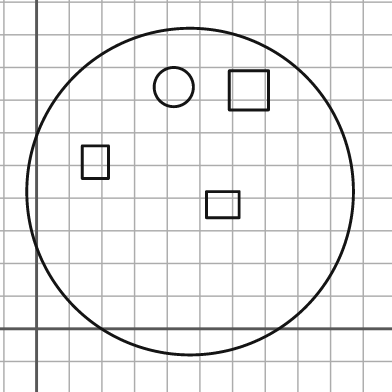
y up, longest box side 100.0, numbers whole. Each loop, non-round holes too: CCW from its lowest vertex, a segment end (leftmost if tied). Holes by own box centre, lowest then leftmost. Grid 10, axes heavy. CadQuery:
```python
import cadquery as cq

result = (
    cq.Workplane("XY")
    .moveTo(47.0, 42.0)
    .circle(50.0)
    .moveTo(52.0, 34.0)
    .lineTo(62.0, 34.0)
    .lineTo(62.0, 42.0)
    .lineTo(52.0, 42.0)
    .close()
    .moveTo(14.0, 46.0)
    .lineTo(22.0, 46.0)
    .lineTo(22.0, 56.0)
    .lineTo(14.0, 56.0)
    .close()
    .moveTo(59.0, 67.0)
    .lineTo(71.0, 67.0)
    .lineTo(71.0, 79.0)
    .lineTo(59.0, 79.0)
    .close()
    .moveTo(42.0, 74.0)
    .circle(6.0)
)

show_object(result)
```